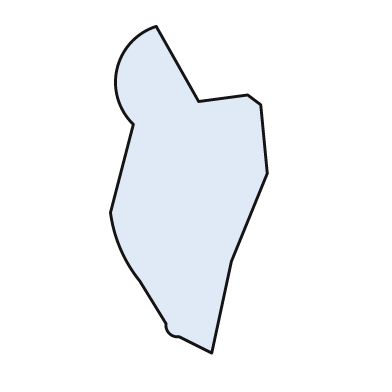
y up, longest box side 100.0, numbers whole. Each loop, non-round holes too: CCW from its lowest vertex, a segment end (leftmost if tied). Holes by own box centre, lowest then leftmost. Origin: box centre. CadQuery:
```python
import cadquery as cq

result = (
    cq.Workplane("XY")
    .moveTo(7.0, -50.0)
    .lineTo(13.0, -22.0)
    .lineTo(24.0, 5.0)
    .lineTo(22.0, 26.0)
    .lineTo(18.0, 29.0)
    .lineTo(3.0, 27.0)
    .lineTo(-10.0, 50.0)
    .threePointArc((-22.0, 37.0), (-17.0, 20.0))
    .lineTo(-24.0, -7.0)
    .threePointArc((-21.0, -18.0), (-15.0, -28.0))
    .lineTo(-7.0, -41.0)
    .threePointArc((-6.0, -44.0), (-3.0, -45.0))
    .close()
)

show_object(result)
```